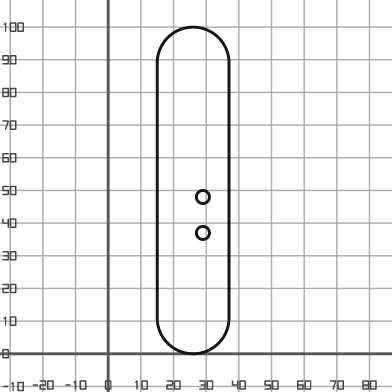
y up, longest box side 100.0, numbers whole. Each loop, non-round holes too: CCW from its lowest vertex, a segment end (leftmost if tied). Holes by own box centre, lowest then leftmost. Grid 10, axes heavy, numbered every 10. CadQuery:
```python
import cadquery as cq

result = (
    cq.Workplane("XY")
    .moveTo(15.0, 11.0)
    .threePointArc((26.0, 0.0), (37.0, 11.0))
    .lineTo(37.0, 89.0)
    .threePointArc((26.0, 100.0), (15.0, 89.0))
    .close()
    .moveTo(29.0, 37.0)
    .circle(2.0)
    .moveTo(29.0, 48.0)
    .circle(2.0)
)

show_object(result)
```